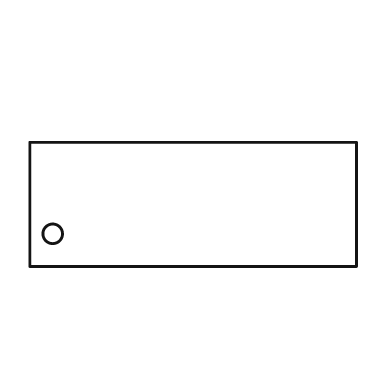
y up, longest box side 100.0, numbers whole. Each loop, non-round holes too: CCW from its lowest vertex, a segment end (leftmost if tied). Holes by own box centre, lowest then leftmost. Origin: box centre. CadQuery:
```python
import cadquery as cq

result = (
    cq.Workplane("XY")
    .moveTo(-50.0, -19.0)
    .lineTo(50.0, -19.0)
    .lineTo(50.0, 19.0)
    .lineTo(-50.0, 19.0)
    .close()
    .moveTo(-43.0, -9.0)
    .circle(3.0)
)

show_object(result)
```